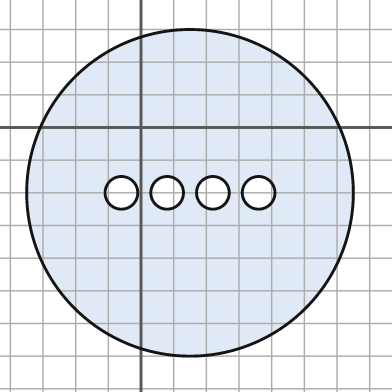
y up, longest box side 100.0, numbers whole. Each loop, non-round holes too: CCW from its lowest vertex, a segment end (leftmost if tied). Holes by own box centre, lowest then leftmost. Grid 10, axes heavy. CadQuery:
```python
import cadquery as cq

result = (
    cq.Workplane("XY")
    .moveTo(15.0, -20.0)
    .circle(50.0)
    .moveTo(-6.0, -20.0)
    .circle(5.0)
    .moveTo(8.0, -20.0)
    .circle(5.0)
    .moveTo(22.0, -20.0)
    .circle(5.0)
    .moveTo(36.0, -20.0)
    .circle(5.0)
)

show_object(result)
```